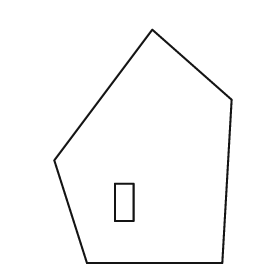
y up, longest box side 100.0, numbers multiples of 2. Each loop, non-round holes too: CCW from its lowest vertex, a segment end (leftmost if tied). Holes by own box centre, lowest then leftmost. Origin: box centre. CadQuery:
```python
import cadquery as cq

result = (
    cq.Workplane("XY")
    .moveTo(-24.0, -50.0)
    .lineTo(34.0, -50.0)
    .lineTo(38.0, 20.0)
    .lineTo(4.0, 50.0)
    .lineTo(-38.0, -6.0)
    .close()
    .moveTo(-12.0, -32.0)
    .lineTo(-4.0, -32.0)
    .lineTo(-4.0, -16.0)
    .lineTo(-12.0, -16.0)
    .close()
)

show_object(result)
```